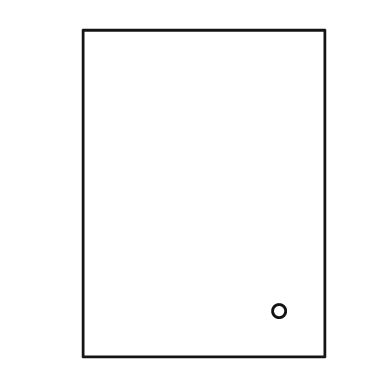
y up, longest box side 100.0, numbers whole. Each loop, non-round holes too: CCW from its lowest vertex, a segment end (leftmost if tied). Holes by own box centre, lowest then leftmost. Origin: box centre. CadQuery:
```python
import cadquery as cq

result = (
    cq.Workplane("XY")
    .moveTo(-37.0, -50.0)
    .lineTo(37.0, -50.0)
    .lineTo(37.0, 50.0)
    .lineTo(-37.0, 50.0)
    .close()
    .moveTo(23.0, -36.0)
    .circle(2.0)
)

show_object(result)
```